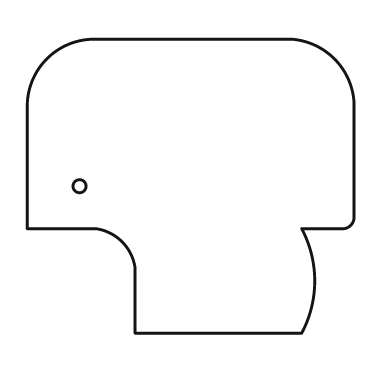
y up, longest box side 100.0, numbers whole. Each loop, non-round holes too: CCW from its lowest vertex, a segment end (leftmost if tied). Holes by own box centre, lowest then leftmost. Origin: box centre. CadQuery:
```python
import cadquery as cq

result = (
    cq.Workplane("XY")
    .moveTo(-17.0, -45.0)
    .lineTo(34.0, -45.0)
    .threePointArc((38.0, -29.0), (34.0, -13.0))
    .lineTo(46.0, -13.0)
    .threePointArc((49.0, -12.0), (50.0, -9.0))
    .lineTo(50.0, 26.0)
    .threePointArc((44.0, 39.0), (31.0, 45.0))
    .lineTo(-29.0, 45.0)
    .threePointArc((-44.0, 39.0), (-50.0, 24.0))
    .lineTo(-50.0, -13.0)
    .lineTo(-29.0, -13.0)
    .threePointArc((-21.0, -17.0), (-17.0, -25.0))
    .close()
    .moveTo(-34.0, 0.0)
    .circle(2.0)
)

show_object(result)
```